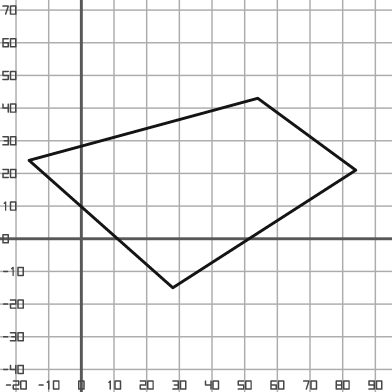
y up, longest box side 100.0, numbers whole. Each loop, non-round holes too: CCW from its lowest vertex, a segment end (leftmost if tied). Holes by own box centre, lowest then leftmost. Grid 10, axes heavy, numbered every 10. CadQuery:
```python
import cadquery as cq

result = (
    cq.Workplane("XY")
    .moveTo(28.0, -15.0)
    .lineTo(84.0, 21.0)
    .lineTo(54.0, 43.0)
    .lineTo(-16.0, 24.0)
    .close()
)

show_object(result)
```